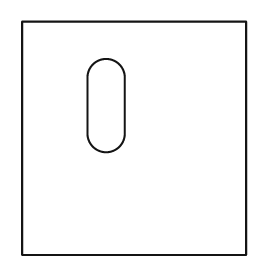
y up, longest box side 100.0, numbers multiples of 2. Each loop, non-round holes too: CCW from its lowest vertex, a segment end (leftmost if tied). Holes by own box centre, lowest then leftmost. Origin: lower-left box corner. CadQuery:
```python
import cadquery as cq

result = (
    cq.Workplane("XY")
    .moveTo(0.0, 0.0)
    .lineTo(96.0, 0.0)
    .lineTo(96.0, 100.0)
    .lineTo(0.0, 100.0)
    .close()
    .moveTo(28.0, 52.0)
    .threePointArc((36.0, 44.0), (44.0, 52.0))
    .lineTo(44.0, 76.0)
    .threePointArc((36.0, 84.0), (28.0, 76.0))
    .close()
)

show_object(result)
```